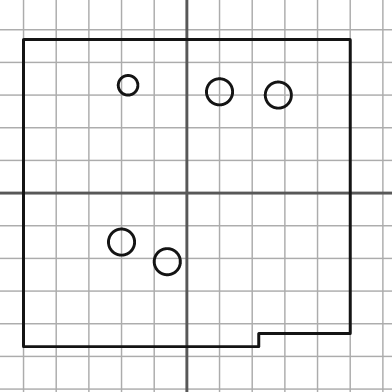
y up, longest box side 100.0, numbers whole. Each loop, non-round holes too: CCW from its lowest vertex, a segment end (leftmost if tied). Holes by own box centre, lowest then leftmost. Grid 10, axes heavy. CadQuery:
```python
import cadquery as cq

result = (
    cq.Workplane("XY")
    .moveTo(-50.0, -47.0)
    .lineTo(22.0, -47.0)
    .lineTo(22.0, -43.0)
    .lineTo(50.0, -43.0)
    .lineTo(50.0, 47.0)
    .lineTo(-50.0, 47.0)
    .close()
    .moveTo(-6.0, -21.0)
    .circle(4.0)
    .moveTo(-20.0, -15.0)
    .circle(4.0)
    .moveTo(28.0, 30.0)
    .circle(4.0)
    .moveTo(10.0, 31.0)
    .circle(4.0)
    .moveTo(-18.0, 33.0)
    .circle(3.0)
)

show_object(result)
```